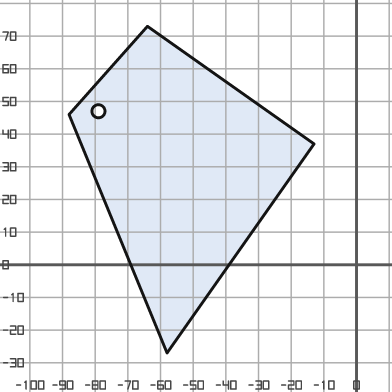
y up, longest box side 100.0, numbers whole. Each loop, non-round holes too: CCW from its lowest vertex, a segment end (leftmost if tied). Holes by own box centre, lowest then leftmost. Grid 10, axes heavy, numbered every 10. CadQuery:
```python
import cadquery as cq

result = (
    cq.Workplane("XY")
    .moveTo(-58.0, -27.0)
    .lineTo(-13.0, 37.0)
    .lineTo(-64.0, 73.0)
    .lineTo(-88.0, 46.0)
    .close()
    .moveTo(-79.0, 47.0)
    .circle(2.0)
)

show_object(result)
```